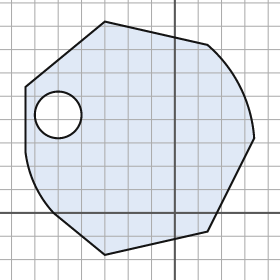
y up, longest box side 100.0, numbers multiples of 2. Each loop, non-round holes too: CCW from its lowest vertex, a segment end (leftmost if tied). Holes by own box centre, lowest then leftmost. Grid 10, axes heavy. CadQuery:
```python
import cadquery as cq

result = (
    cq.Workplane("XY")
    .moveTo(-30.0, -18.0)
    .lineTo(14.0, -8.0)
    .lineTo(34.0, 32.0)
    .threePointArc((28.0, 54.0), (14.0, 72.0))
    .lineTo(-30.0, 82.0)
    .lineTo(-64.0, 54.0)
    .lineTo(-64.0, 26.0)
    .threePointArc((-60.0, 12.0), (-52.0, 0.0))
    .close()
    .moveTo(-50.0, 42.0)
    .circle(10.0)
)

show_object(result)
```